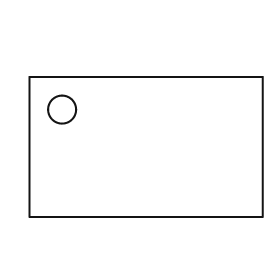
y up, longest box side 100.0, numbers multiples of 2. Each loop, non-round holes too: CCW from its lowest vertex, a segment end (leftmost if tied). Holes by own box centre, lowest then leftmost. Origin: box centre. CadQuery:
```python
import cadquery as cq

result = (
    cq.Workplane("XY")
    .moveTo(-50.0, -30.0)
    .lineTo(50.0, -30.0)
    .lineTo(50.0, 30.0)
    .lineTo(-50.0, 30.0)
    .close()
    .moveTo(-36.0, 16.0)
    .circle(6.0)
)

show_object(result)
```